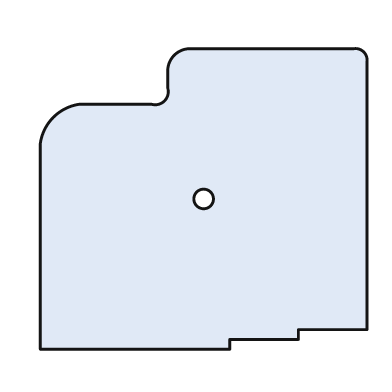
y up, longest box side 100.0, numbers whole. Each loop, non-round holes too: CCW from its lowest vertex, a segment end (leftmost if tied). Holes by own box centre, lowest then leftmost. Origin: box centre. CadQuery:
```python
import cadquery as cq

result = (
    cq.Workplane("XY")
    .moveTo(-50.0, -46.0)
    .lineTo(8.0, -46.0)
    .lineTo(8.0, -43.0)
    .lineTo(29.0, -43.0)
    .lineTo(29.0, -40.0)
    .lineTo(50.0, -40.0)
    .lineTo(50.0, 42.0)
    .threePointArc((49.0, 45.0), (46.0, 46.0))
    .lineTo(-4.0, 46.0)
    .threePointArc((-9.0, 44.0), (-11.0, 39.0))
    .lineTo(-11.0, 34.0)
    .threePointArc((-12.0, 30.0), (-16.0, 29.0))
    .lineTo(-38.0, 29.0)
    .threePointArc((-46.0, 25.0), (-50.0, 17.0))
    .close()
    .moveTo(0.0, 0.0)
    .circle(3.0)
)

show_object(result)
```